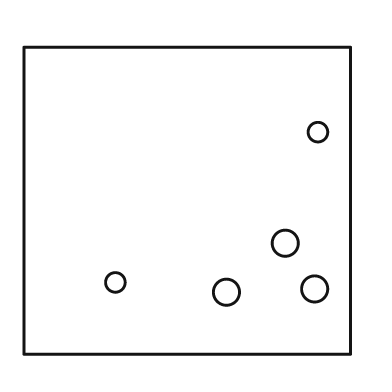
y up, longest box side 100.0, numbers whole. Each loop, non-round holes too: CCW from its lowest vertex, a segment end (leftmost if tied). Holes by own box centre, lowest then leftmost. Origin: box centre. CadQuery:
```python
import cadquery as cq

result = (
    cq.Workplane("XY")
    .moveTo(-50.0, -47.0)
    .lineTo(50.0, -47.0)
    .lineTo(50.0, 47.0)
    .lineTo(-50.0, 47.0)
    .close()
    .moveTo(12.0, -28.0)
    .circle(4.0)
    .moveTo(39.0, -27.0)
    .circle(4.0)
    .moveTo(-22.0, -25.0)
    .circle(3.0)
    .moveTo(30.0, -13.0)
    .circle(4.0)
    .moveTo(40.0, 21.0)
    .circle(3.0)
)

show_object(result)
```